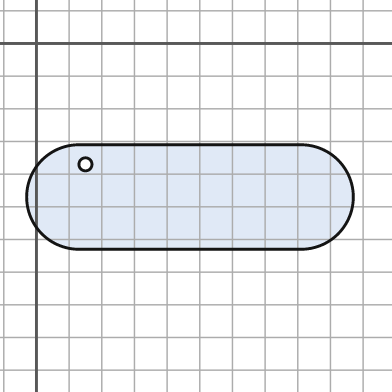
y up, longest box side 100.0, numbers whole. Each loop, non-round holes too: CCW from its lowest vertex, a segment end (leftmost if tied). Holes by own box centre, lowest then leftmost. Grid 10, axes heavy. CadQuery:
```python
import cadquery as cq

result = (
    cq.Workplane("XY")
    .moveTo(13.0, -63.0)
    .lineTo(81.0, -63.0)
    .threePointArc((97.0, -47.0), (81.0, -31.0))
    .lineTo(13.0, -31.0)
    .threePointArc((-3.0, -47.0), (13.0, -63.0))
    .close()
    .moveTo(15.0, -37.0)
    .circle(2.0)
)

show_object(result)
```